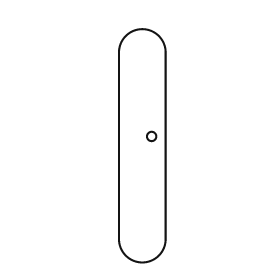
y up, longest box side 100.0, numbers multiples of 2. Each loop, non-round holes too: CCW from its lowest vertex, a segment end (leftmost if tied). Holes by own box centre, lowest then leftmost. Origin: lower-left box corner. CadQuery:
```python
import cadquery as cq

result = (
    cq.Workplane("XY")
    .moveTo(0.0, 10.0)
    .threePointArc((10.0, 0.0), (20.0, 10.0))
    .lineTo(20.0, 90.0)
    .threePointArc((10.0, 100.0), (0.0, 90.0))
    .close()
    .moveTo(14.0, 54.0)
    .circle(2.0)
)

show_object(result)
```